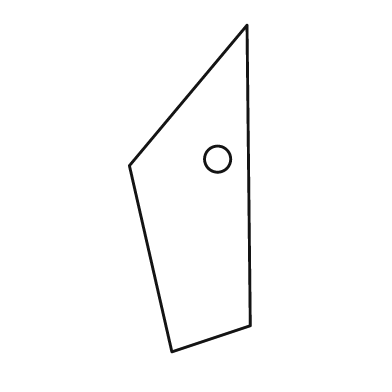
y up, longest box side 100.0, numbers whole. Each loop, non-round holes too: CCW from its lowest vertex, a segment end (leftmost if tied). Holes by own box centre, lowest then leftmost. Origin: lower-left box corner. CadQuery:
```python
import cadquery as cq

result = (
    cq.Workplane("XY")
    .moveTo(13.0, 0.0)
    .lineTo(37.0, 8.0)
    .lineTo(36.0, 100.0)
    .lineTo(0.0, 57.0)
    .close()
    .moveTo(27.0, 59.0)
    .circle(4.0)
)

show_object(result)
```